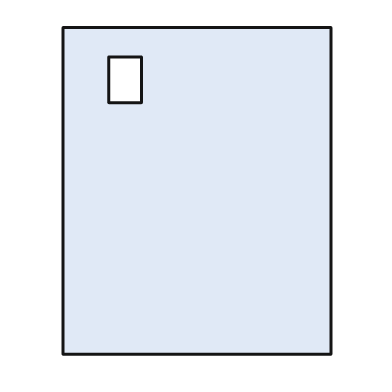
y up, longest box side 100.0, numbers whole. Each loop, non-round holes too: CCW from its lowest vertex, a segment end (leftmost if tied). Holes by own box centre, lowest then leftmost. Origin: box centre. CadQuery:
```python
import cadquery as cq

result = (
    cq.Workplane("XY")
    .moveTo(-41.0, -50.0)
    .lineTo(41.0, -50.0)
    .lineTo(41.0, 50.0)
    .lineTo(-41.0, 50.0)
    .close()
    .moveTo(-27.0, 27.0)
    .lineTo(-17.0, 27.0)
    .lineTo(-17.0, 41.0)
    .lineTo(-27.0, 41.0)
    .close()
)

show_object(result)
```